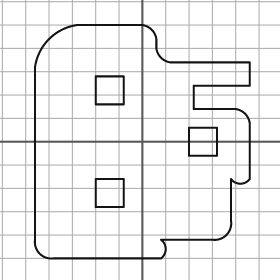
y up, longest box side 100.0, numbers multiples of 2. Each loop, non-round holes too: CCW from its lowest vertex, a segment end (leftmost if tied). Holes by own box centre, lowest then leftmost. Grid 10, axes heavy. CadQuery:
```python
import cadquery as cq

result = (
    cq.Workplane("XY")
    .moveTo(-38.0, -50.0)
    .lineTo(8.0, -50.0)
    .threePointArc((10.0, -46.0), (8.0, -42.0))
    .lineTo(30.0, -42.0)
    .threePointArc((36.0, -40.0), (38.0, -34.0))
    .lineTo(38.0, -16.0)
    .threePointArc((42.0, -18.0), (46.0, -16.0))
    .lineTo(46.0, 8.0)
    .threePointArc((44.0, 12.0), (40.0, 14.0))
    .lineTo(22.0, 14.0)
    .lineTo(22.0, 24.0)
    .lineTo(46.0, 24.0)
    .lineTo(46.0, 34.0)
    .lineTo(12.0, 34.0)
    .threePointArc((8.0, 36.0), (6.0, 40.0))
    .lineTo(6.0, 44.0)
    .threePointArc((4.0, 48.0), (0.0, 50.0))
    .lineTo(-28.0, 50.0)
    .threePointArc((-40.0, 44.0), (-46.0, 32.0))
    .lineTo(-46.0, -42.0)
    .threePointArc((-44.0, -48.0), (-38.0, -50.0))
    .close()
    .moveTo(-20.0, -28.0)
    .lineTo(-8.0, -28.0)
    .lineTo(-8.0, -16.0)
    .lineTo(-20.0, -16.0)
    .close()
    .moveTo(20.0, -6.0)
    .lineTo(32.0, -6.0)
    .lineTo(32.0, 6.0)
    .lineTo(20.0, 6.0)
    .close()
    .moveTo(-20.0, 16.0)
    .lineTo(-8.0, 16.0)
    .lineTo(-8.0, 28.0)
    .lineTo(-20.0, 28.0)
    .close()
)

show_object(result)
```